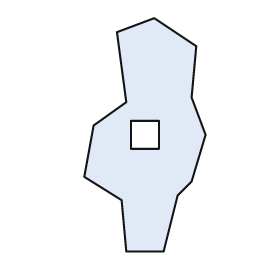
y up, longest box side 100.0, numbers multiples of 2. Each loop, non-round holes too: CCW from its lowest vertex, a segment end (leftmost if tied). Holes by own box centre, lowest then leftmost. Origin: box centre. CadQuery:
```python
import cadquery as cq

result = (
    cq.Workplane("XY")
    .moveTo(-8.0, -50.0)
    .lineTo(8.0, -50.0)
    .lineTo(14.0, -26.0)
    .lineTo(20.0, -20.0)
    .lineTo(26.0, 0.0)
    .lineTo(20.0, 16.0)
    .lineTo(22.0, 38.0)
    .lineTo(4.0, 50.0)
    .lineTo(-12.0, 44.0)
    .lineTo(-8.0, 14.0)
    .lineTo(-22.0, 4.0)
    .lineTo(-26.0, -18.0)
    .lineTo(-10.0, -28.0)
    .close()
    .moveTo(-6.0, -6.0)
    .lineTo(6.0, -6.0)
    .lineTo(6.0, 6.0)
    .lineTo(-6.0, 6.0)
    .close()
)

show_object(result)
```